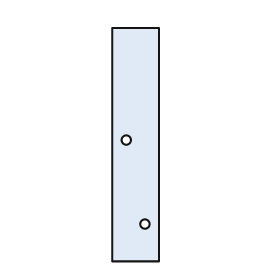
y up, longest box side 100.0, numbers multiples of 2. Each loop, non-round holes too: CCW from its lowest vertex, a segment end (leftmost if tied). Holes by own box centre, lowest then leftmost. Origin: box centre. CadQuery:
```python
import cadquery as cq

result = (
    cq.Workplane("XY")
    .moveTo(-10.0, -50.0)
    .lineTo(10.0, -50.0)
    .lineTo(10.0, 50.0)
    .lineTo(-10.0, 50.0)
    .close()
    .moveTo(4.0, -34.0)
    .circle(2.0)
    .moveTo(-4.0, 2.0)
    .circle(2.0)
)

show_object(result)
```